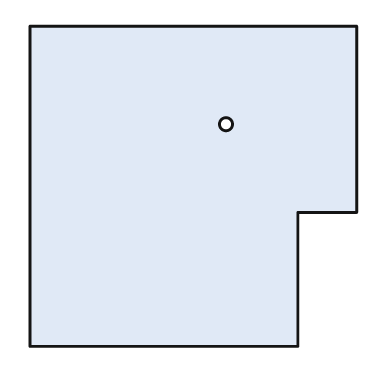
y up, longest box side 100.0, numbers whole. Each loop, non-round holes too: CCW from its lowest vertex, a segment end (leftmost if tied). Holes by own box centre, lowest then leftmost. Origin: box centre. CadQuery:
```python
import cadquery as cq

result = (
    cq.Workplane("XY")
    .moveTo(-50.0, -49.0)
    .lineTo(32.0, -49.0)
    .lineTo(32.0, -8.0)
    .lineTo(50.0, -8.0)
    .lineTo(50.0, 49.0)
    .lineTo(-50.0, 49.0)
    .close()
    .moveTo(10.0, 19.0)
    .circle(2.0)
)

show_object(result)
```